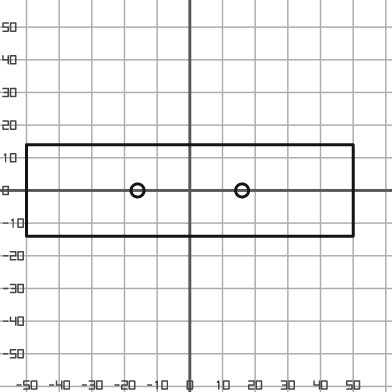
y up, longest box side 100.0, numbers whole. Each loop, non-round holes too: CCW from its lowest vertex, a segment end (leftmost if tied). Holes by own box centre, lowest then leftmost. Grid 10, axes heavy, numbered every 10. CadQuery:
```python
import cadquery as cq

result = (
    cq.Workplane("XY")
    .moveTo(-50.0, -14.0)
    .lineTo(50.0, -14.0)
    .lineTo(50.0, 14.0)
    .lineTo(-50.0, 14.0)
    .close()
    .moveTo(-16.0, 0.0)
    .circle(2.0)
    .moveTo(16.0, 0.0)
    .circle(2.0)
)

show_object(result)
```